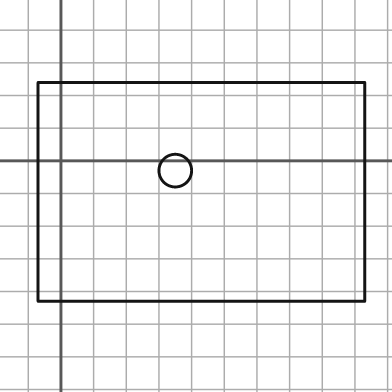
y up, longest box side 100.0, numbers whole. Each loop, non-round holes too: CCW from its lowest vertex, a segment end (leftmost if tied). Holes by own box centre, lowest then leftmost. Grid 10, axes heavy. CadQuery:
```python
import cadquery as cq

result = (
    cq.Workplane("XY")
    .moveTo(-7.0, -43.0)
    .lineTo(93.0, -43.0)
    .lineTo(93.0, 24.0)
    .lineTo(-7.0, 24.0)
    .close()
    .moveTo(35.0, -3.0)
    .circle(5.0)
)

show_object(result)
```